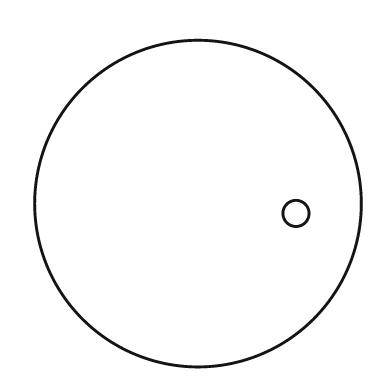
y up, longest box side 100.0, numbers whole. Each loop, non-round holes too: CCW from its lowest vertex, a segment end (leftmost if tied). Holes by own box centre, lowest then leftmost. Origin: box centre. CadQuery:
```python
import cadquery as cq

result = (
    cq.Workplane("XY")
    .moveTo(0.0, 0.0)
    .circle(50.0)
    .moveTo(30.0, -3.0)
    .circle(4.0)
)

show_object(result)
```